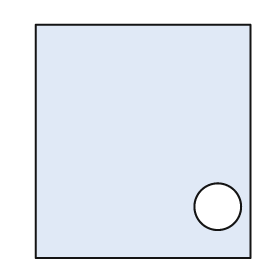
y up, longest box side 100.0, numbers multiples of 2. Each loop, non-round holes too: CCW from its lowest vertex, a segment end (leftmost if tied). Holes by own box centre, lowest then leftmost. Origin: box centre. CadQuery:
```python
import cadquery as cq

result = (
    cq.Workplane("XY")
    .moveTo(-46.0, -50.0)
    .lineTo(46.0, -50.0)
    .lineTo(46.0, 50.0)
    .lineTo(-46.0, 50.0)
    .close()
    .moveTo(32.0, -28.0)
    .circle(10.0)
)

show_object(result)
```